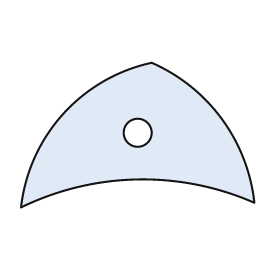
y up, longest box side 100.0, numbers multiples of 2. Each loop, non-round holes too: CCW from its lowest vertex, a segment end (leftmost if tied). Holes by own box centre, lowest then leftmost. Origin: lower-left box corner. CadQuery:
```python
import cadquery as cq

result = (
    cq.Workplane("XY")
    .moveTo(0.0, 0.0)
    .threePointArc((50.0, 12.0), (100.0, 2.0))
    .threePointArc((86.0, 38.0), (56.0, 62.0))
    .threePointArc((18.0, 40.0), (0.0, 0.0))
    .close()
    .moveTo(50.0, 32.0)
    .circle(6.0)
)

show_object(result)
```